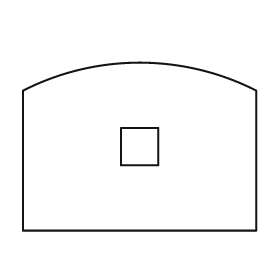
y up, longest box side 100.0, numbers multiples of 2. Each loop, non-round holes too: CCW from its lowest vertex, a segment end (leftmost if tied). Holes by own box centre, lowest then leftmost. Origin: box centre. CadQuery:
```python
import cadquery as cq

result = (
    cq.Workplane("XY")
    .moveTo(-50.0, -36.0)
    .lineTo(50.0, -36.0)
    .lineTo(50.0, 24.0)
    .threePointArc((0.0, 36.0), (-50.0, 24.0))
    .close()
    .moveTo(-8.0, -8.0)
    .lineTo(8.0, -8.0)
    .lineTo(8.0, 8.0)
    .lineTo(-8.0, 8.0)
    .close()
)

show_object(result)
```